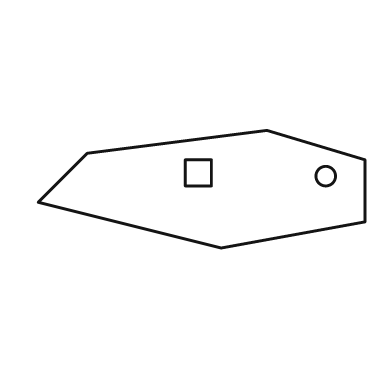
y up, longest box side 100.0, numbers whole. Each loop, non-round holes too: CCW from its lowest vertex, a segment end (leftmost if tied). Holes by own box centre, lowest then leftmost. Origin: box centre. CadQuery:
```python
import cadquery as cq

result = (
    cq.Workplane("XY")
    .moveTo(6.0, -18.0)
    .lineTo(50.0, -10.0)
    .lineTo(50.0, 9.0)
    .lineTo(20.0, 18.0)
    .lineTo(-35.0, 11.0)
    .lineTo(-50.0, -4.0)
    .close()
    .moveTo(38.0, 4.0)
    .circle(3.0)
    .moveTo(-5.0, 1.0)
    .lineTo(3.0, 1.0)
    .lineTo(3.0, 9.0)
    .lineTo(-5.0, 9.0)
    .close()
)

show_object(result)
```